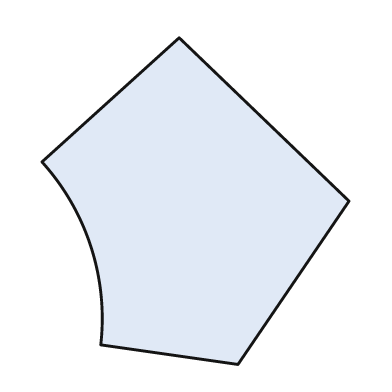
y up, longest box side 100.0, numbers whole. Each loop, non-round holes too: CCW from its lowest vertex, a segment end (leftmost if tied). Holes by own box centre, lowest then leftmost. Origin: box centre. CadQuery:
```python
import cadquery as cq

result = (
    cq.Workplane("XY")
    .moveTo(13.0, -50.0)
    .lineTo(47.0, 0.0)
    .lineTo(-5.0, 50.0)
    .lineTo(-47.0, 12.0)
    .threePointArc((-32.0, -14.0), (-29.0, -44.0))
    .close()
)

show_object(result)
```